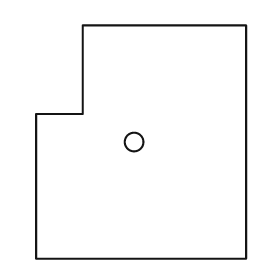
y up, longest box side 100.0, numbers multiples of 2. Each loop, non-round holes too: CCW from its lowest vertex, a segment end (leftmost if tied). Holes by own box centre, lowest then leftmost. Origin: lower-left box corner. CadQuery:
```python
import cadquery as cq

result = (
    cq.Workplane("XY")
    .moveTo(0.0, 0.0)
    .lineTo(90.0, 0.0)
    .lineTo(90.0, 100.0)
    .lineTo(20.0, 100.0)
    .lineTo(20.0, 62.0)
    .lineTo(0.0, 62.0)
    .close()
    .moveTo(42.0, 50.0)
    .circle(4.0)
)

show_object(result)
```